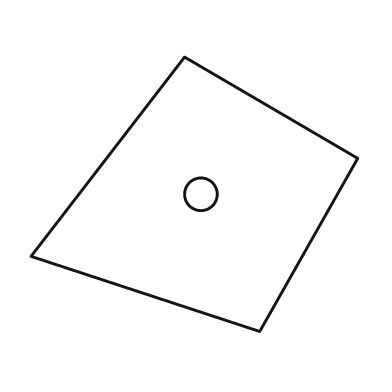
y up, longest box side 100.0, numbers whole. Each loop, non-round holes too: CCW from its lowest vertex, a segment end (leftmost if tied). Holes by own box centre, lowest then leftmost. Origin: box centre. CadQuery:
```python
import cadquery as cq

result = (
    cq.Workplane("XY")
    .moveTo(20.0, -42.0)
    .lineTo(50.0, 11.0)
    .lineTo(-3.0, 42.0)
    .lineTo(-50.0, -19.0)
    .close()
    .moveTo(2.0, 0.0)
    .circle(5.0)
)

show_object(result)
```